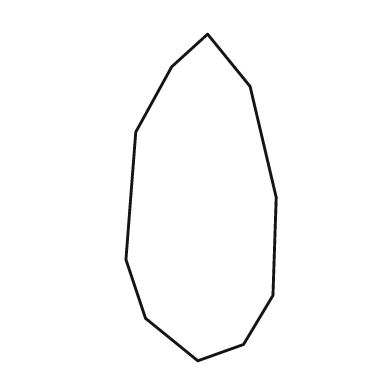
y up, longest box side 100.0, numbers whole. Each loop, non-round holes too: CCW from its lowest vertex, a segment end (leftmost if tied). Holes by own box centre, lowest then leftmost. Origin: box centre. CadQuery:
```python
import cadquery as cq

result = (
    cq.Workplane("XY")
    .moveTo(-1.0, -50.0)
    .lineTo(13.0, -45.0)
    .lineTo(22.0, -30.0)
    .lineTo(23.0, 0.0)
    .lineTo(15.0, 34.0)
    .lineTo(2.0, 50.0)
    .lineTo(-9.0, 40.0)
    .lineTo(-20.0, 20.0)
    .lineTo(-23.0, -19.0)
    .lineTo(-17.0, -37.0)
    .close()
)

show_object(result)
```